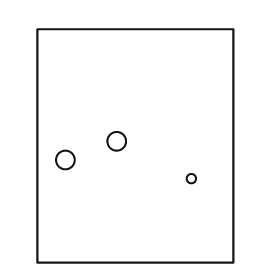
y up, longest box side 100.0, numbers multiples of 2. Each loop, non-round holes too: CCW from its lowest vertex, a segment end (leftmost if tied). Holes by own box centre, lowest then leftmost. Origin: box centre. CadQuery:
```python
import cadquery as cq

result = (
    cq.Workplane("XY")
    .moveTo(-42.0, -50.0)
    .lineTo(42.0, -50.0)
    .lineTo(42.0, 50.0)
    .lineTo(-42.0, 50.0)
    .close()
    .moveTo(24.0, -14.0)
    .circle(2.0)
    .moveTo(-30.0, -6.0)
    .circle(4.0)
    .moveTo(-8.0, 2.0)
    .circle(4.0)
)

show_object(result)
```